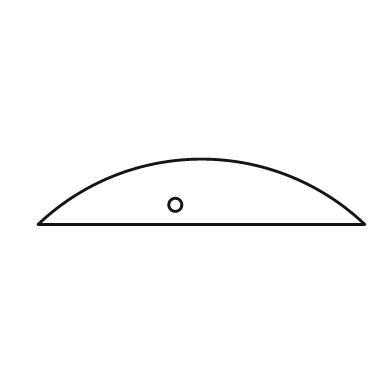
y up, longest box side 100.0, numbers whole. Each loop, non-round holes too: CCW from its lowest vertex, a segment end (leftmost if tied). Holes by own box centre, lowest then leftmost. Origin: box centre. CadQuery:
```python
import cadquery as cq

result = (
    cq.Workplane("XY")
    .moveTo(-50.0, -10.0)
    .lineTo(50.0, -10.0)
    .threePointArc((0.0, 10.0), (-50.0, -10.0))
    .close()
    .moveTo(-8.0, -4.0)
    .circle(2.0)
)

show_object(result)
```